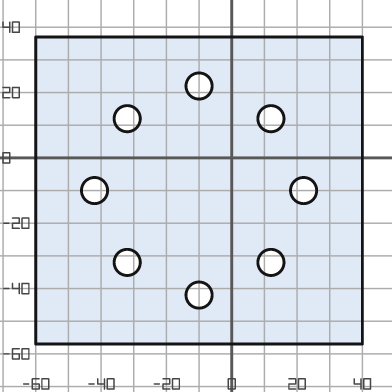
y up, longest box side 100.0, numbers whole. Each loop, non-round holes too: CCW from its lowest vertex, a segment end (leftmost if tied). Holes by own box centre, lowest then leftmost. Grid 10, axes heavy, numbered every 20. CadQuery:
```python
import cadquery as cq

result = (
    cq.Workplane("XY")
    .moveTo(-60.0, -57.0)
    .lineTo(40.0, -57.0)
    .lineTo(40.0, 37.0)
    .lineTo(-60.0, 37.0)
    .close()
    .moveTo(-10.0, -42.0)
    .circle(4.0)
    .moveTo(-32.0, -32.0)
    .circle(4.0)
    .moveTo(12.0, -32.0)
    .circle(4.0)
    .moveTo(-42.0, -10.0)
    .circle(4.0)
    .moveTo(22.0, -10.0)
    .circle(4.0)
    .moveTo(-32.0, 12.0)
    .circle(4.0)
    .moveTo(12.0, 12.0)
    .circle(4.0)
    .moveTo(-10.0, 22.0)
    .circle(4.0)
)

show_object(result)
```